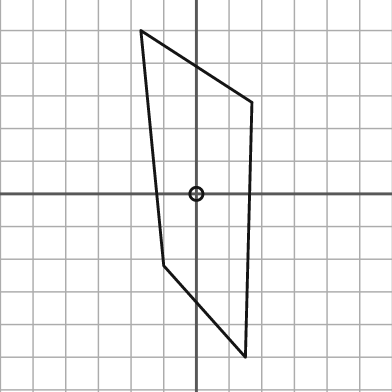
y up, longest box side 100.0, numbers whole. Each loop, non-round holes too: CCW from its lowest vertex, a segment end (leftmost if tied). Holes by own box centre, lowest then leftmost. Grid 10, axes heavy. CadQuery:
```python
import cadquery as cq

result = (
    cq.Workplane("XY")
    .moveTo(15.0, -50.0)
    .lineTo(17.0, 28.0)
    .lineTo(-17.0, 50.0)
    .lineTo(-10.0, -22.0)
    .close()
    .moveTo(0.0, 0.0)
    .circle(2.0)
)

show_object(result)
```